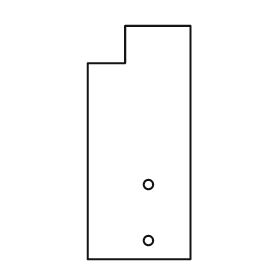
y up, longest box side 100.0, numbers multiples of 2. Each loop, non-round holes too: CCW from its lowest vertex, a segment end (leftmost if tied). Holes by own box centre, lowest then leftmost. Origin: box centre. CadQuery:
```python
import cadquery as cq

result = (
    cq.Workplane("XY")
    .moveTo(-22.0, -50.0)
    .lineTo(22.0, -50.0)
    .lineTo(22.0, 50.0)
    .lineTo(-6.0, 50.0)
    .lineTo(-6.0, 34.0)
    .lineTo(-22.0, 34.0)
    .close()
    .moveTo(4.0, -42.0)
    .circle(2.0)
    .moveTo(4.0, -18.0)
    .circle(2.0)
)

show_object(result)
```